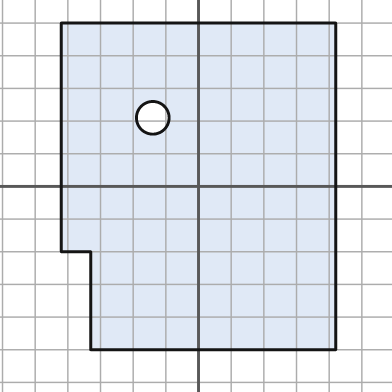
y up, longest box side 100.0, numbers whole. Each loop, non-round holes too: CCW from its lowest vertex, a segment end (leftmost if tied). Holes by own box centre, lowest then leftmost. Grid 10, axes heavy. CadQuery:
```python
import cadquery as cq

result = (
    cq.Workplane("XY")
    .moveTo(-33.0, -50.0)
    .lineTo(42.0, -50.0)
    .lineTo(42.0, 50.0)
    .lineTo(-42.0, 50.0)
    .lineTo(-42.0, -20.0)
    .lineTo(-33.0, -20.0)
    .close()
    .moveTo(-14.0, 21.0)
    .circle(5.0)
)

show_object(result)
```